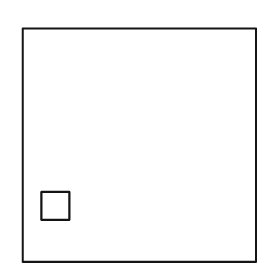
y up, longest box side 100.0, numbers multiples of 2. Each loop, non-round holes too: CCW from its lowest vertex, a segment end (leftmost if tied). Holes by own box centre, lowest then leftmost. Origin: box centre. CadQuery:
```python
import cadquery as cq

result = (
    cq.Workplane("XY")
    .moveTo(-50.0, -50.0)
    .lineTo(50.0, -50.0)
    .lineTo(50.0, 50.0)
    .lineTo(-50.0, 50.0)
    .close()
    .moveTo(-42.0, -32.0)
    .lineTo(-30.0, -32.0)
    .lineTo(-30.0, -20.0)
    .lineTo(-42.0, -20.0)
    .close()
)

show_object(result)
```